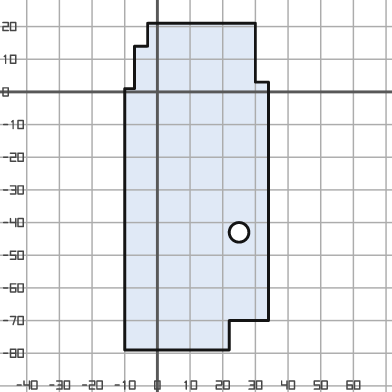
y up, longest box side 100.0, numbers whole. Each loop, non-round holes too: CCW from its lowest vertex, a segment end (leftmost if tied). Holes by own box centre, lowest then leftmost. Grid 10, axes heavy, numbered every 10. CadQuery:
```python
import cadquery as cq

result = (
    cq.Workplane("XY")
    .moveTo(-10.0, -79.0)
    .lineTo(22.0, -79.0)
    .lineTo(22.0, -70.0)
    .lineTo(34.0, -70.0)
    .lineTo(34.0, 3.0)
    .lineTo(30.0, 3.0)
    .lineTo(30.0, 21.0)
    .lineTo(-3.0, 21.0)
    .lineTo(-3.0, 14.0)
    .lineTo(-7.0, 14.0)
    .lineTo(-7.0, 1.0)
    .lineTo(-10.0, 1.0)
    .close()
    .moveTo(25.0, -43.0)
    .circle(3.0)
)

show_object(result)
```